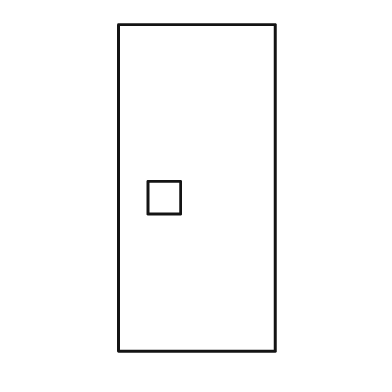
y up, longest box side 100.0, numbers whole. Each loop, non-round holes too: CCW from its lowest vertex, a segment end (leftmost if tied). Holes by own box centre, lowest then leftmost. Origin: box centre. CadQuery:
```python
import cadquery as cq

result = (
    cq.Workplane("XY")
    .moveTo(-24.0, -50.0)
    .lineTo(24.0, -50.0)
    .lineTo(24.0, 50.0)
    .lineTo(-24.0, 50.0)
    .close()
    .moveTo(-15.0, -8.0)
    .lineTo(-5.0, -8.0)
    .lineTo(-5.0, 2.0)
    .lineTo(-15.0, 2.0)
    .close()
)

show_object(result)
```